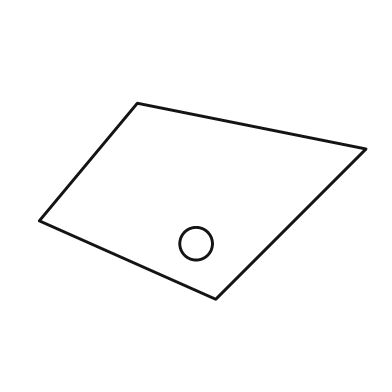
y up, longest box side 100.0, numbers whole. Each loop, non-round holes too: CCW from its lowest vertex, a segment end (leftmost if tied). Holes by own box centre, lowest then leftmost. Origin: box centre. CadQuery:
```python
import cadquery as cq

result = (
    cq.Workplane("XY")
    .moveTo(4.0, -30.0)
    .lineTo(50.0, 16.0)
    .lineTo(-20.0, 30.0)
    .lineTo(-50.0, -6.0)
    .close()
    .moveTo(-2.0, -13.0)
    .circle(5.0)
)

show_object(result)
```